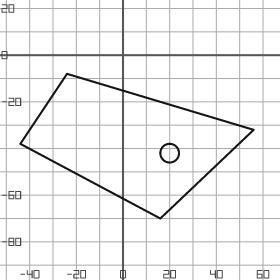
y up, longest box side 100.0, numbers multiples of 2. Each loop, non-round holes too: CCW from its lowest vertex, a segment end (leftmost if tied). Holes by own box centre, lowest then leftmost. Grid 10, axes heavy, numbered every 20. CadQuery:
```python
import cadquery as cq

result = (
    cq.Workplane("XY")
    .moveTo(16.0, -70.0)
    .lineTo(56.0, -32.0)
    .lineTo(-24.0, -8.0)
    .lineTo(-44.0, -38.0)
    .close()
    .moveTo(20.0, -42.0)
    .circle(4.0)
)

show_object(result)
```